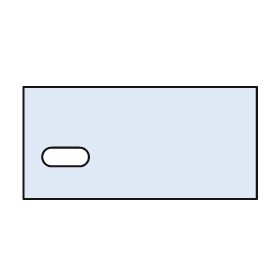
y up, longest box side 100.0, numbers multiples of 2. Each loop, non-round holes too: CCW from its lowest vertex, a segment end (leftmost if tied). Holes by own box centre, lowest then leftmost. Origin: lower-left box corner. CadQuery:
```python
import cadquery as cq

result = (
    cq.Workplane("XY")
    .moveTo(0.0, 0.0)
    .lineTo(100.0, 0.0)
    .lineTo(100.0, 48.0)
    .lineTo(0.0, 48.0)
    .close()
    .moveTo(12.0, 14.0)
    .lineTo(24.0, 14.0)
    .threePointArc((28.0, 18.0), (24.0, 22.0))
    .lineTo(12.0, 22.0)
    .threePointArc((8.0, 18.0), (12.0, 14.0))
    .close()
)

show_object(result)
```